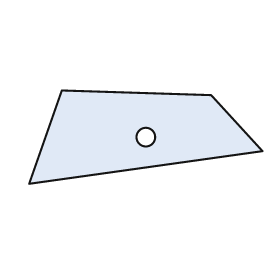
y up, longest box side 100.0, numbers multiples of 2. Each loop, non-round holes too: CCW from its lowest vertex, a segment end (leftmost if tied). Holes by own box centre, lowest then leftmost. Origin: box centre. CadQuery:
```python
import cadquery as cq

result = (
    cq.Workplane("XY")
    .moveTo(-50.0, -20.0)
    .lineTo(50.0, -6.0)
    .lineTo(28.0, 18.0)
    .lineTo(-36.0, 20.0)
    .close()
    .moveTo(0.0, 0.0)
    .circle(4.0)
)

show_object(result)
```